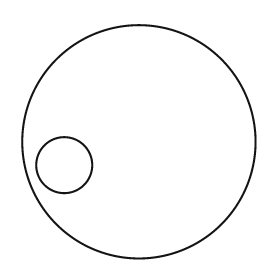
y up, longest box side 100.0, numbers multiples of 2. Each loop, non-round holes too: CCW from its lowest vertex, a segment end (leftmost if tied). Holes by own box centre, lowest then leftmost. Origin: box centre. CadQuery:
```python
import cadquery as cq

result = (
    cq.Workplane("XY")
    .moveTo(0.0, 0.0)
    .circle(50.0)
    .moveTo(-32.0, -10.0)
    .circle(12.0)
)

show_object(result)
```